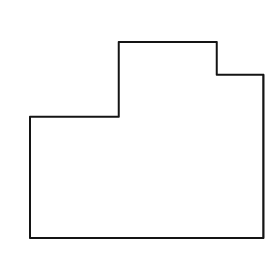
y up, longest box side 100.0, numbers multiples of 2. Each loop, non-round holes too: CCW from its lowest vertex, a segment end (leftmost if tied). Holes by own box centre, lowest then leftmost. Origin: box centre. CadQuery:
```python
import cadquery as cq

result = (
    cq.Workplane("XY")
    .moveTo(-50.0, -42.0)
    .lineTo(50.0, -42.0)
    .lineTo(50.0, 28.0)
    .lineTo(30.0, 28.0)
    .lineTo(30.0, 42.0)
    .lineTo(-12.0, 42.0)
    .lineTo(-12.0, 10.0)
    .lineTo(-50.0, 10.0)
    .close()
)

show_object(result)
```